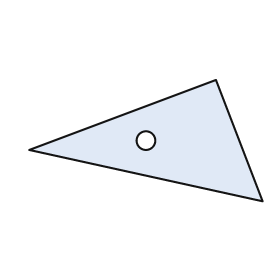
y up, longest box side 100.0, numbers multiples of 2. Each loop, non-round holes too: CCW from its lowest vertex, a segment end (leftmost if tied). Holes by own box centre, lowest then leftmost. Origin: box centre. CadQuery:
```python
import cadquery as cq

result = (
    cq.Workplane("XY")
    .moveTo(50.0, -26.0)
    .lineTo(30.0, 26.0)
    .lineTo(-50.0, -4.0)
    .close()
    .moveTo(0.0, 0.0)
    .circle(4.0)
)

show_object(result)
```